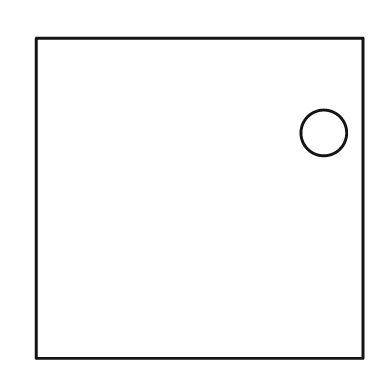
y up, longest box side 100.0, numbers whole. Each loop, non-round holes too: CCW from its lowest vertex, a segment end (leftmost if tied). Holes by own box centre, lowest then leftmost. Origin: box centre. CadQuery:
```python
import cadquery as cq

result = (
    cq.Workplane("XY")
    .moveTo(-50.0, -49.0)
    .lineTo(50.0, -49.0)
    .lineTo(50.0, 49.0)
    .lineTo(-50.0, 49.0)
    .close()
    .moveTo(38.0, 20.0)
    .circle(7.0)
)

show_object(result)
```